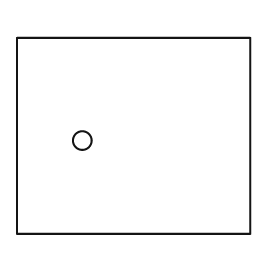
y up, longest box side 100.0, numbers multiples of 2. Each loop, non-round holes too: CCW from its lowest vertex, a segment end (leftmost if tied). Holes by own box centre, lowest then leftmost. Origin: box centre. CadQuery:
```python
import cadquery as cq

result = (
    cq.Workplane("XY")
    .moveTo(-50.0, -42.0)
    .lineTo(50.0, -42.0)
    .lineTo(50.0, 42.0)
    .lineTo(-50.0, 42.0)
    .close()
    .moveTo(-22.0, -2.0)
    .circle(4.0)
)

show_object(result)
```